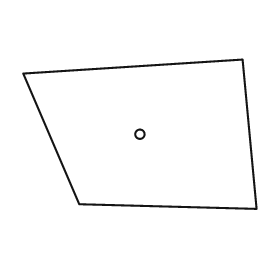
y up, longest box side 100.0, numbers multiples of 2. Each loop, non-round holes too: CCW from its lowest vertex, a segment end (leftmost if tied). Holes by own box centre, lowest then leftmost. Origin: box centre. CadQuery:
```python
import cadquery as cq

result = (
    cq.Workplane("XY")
    .moveTo(50.0, -32.0)
    .lineTo(44.0, 32.0)
    .lineTo(-50.0, 26.0)
    .lineTo(-26.0, -30.0)
    .close()
    .moveTo(0.0, 0.0)
    .circle(2.0)
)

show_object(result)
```